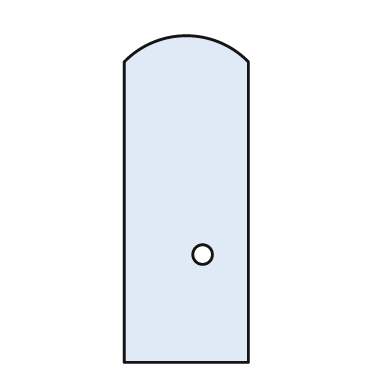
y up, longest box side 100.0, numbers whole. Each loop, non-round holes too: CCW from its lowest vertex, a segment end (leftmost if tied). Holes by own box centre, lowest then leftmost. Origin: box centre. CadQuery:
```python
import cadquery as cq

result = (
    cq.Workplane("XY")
    .moveTo(-19.0, -50.0)
    .lineTo(19.0, -50.0)
    .lineTo(19.0, 42.0)
    .threePointArc((0.0, 50.0), (-19.0, 42.0))
    .close()
    .moveTo(5.0, -17.0)
    .circle(3.0)
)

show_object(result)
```